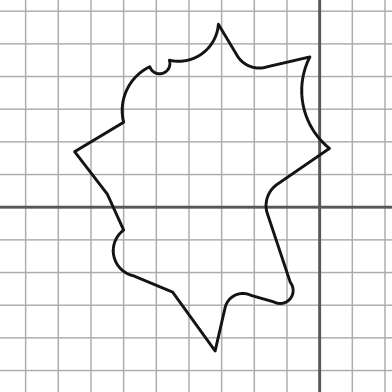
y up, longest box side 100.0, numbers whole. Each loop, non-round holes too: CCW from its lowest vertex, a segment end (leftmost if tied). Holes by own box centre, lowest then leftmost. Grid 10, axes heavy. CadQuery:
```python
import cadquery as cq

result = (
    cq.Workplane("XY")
    .moveTo(-32.0, -44.0)
    .lineTo(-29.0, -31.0)
    .threePointArc((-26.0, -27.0), (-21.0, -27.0))
    .lineTo(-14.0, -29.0)
    .threePointArc((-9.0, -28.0), (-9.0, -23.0))
    .lineTo(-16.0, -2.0)
    .threePointArc((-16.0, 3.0), (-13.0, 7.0))
    .lineTo(3.0, 18.0)
    .threePointArc((-5.0, 31.0), (-3.0, 46.0))
    .lineTo(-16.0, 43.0)
    .threePointArc((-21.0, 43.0), (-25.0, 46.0))
    .lineTo(-31.0, 56.0)
    .threePointArc((-36.0, 47.0), (-46.0, 45.0))
    .threePointArc((-48.0, 41.0), (-52.0, 43.0))
    .threePointArc((-59.0, 36.0), (-60.0, 26.0))
    .lineTo(-75.0, 17.0)
    .lineTo(-65.0, 4.0)
    .lineTo(-60.0, -7.0)
    .threePointArc((-63.0, -15.0), (-57.0, -21.0))
    .lineTo(-45.0, -26.0)
    .close()
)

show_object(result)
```